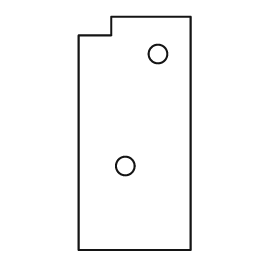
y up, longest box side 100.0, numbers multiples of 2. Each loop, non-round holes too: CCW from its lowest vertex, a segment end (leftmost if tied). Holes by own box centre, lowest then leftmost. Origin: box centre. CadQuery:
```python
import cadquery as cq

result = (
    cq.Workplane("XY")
    .moveTo(-24.0, -50.0)
    .lineTo(24.0, -50.0)
    .lineTo(24.0, 50.0)
    .lineTo(-10.0, 50.0)
    .lineTo(-10.0, 42.0)
    .lineTo(-24.0, 42.0)
    .close()
    .moveTo(-4.0, -14.0)
    .circle(4.0)
    .moveTo(10.0, 34.0)
    .circle(4.0)
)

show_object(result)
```